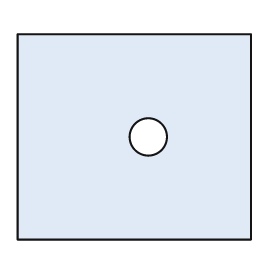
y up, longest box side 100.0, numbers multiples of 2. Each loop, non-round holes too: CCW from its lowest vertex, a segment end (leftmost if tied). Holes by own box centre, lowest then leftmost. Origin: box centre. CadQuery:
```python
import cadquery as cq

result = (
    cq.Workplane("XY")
    .moveTo(-50.0, -44.0)
    .lineTo(50.0, -44.0)
    .lineTo(50.0, 44.0)
    .lineTo(-50.0, 44.0)
    .close()
    .moveTo(6.0, 0.0)
    .circle(8.0)
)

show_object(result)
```